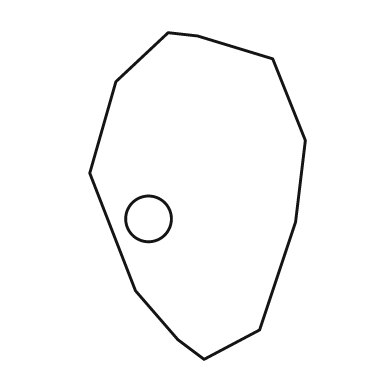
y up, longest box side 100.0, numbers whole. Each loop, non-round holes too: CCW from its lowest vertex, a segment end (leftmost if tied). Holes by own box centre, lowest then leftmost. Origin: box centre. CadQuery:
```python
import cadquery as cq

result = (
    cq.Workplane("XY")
    .moveTo(2.0, -50.0)
    .lineTo(19.0, -41.0)
    .lineTo(30.0, -8.0)
    .lineTo(33.0, 17.0)
    .lineTo(23.0, 42.0)
    .lineTo(0.0, 49.0)
    .lineTo(-9.0, 50.0)
    .lineTo(-25.0, 35.0)
    .lineTo(-33.0, 7.0)
    .lineTo(-19.0, -29.0)
    .lineTo(-6.0, -44.0)
    .close()
    .moveTo(-15.0, -7.0)
    .circle(7.0)
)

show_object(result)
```